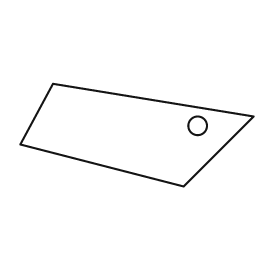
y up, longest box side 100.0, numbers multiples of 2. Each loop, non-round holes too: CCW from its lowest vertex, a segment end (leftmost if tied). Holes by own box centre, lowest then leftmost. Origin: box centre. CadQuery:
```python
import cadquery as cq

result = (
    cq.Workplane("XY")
    .moveTo(20.0, -22.0)
    .lineTo(50.0, 8.0)
    .lineTo(-36.0, 22.0)
    .lineTo(-50.0, -4.0)
    .close()
    .moveTo(26.0, 4.0)
    .circle(4.0)
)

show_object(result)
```